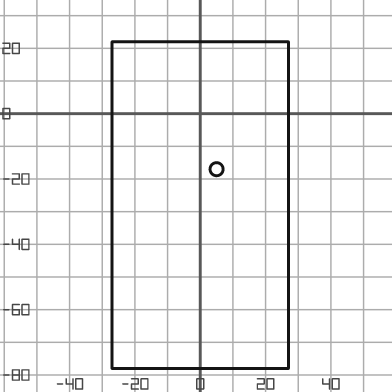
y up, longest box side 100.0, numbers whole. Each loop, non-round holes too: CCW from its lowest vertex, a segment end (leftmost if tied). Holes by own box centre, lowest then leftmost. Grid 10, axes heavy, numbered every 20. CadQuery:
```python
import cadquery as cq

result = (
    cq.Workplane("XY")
    .moveTo(-27.0, -78.0)
    .lineTo(27.0, -78.0)
    .lineTo(27.0, 22.0)
    .lineTo(-27.0, 22.0)
    .close()
    .moveTo(5.0, -17.0)
    .circle(2.0)
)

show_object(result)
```